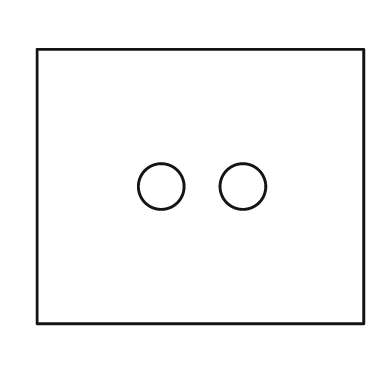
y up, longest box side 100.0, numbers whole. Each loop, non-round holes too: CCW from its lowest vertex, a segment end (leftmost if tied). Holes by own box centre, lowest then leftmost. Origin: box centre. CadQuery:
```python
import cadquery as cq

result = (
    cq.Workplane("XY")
    .moveTo(-50.0, -42.0)
    .lineTo(50.0, -42.0)
    .lineTo(50.0, 42.0)
    .lineTo(-50.0, 42.0)
    .close()
    .moveTo(-12.0, 0.0)
    .circle(7.0)
    .moveTo(13.0, 0.0)
    .circle(7.0)
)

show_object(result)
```